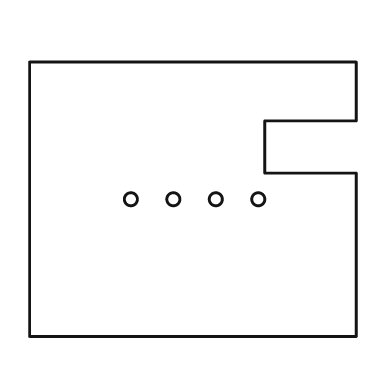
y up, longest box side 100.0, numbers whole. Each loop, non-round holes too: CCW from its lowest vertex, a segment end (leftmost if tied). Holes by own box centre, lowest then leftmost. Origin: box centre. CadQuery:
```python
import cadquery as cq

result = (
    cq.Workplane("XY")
    .moveTo(-50.0, -42.0)
    .lineTo(50.0, -42.0)
    .lineTo(50.0, 8.0)
    .lineTo(22.0, 8.0)
    .lineTo(22.0, 24.0)
    .lineTo(50.0, 24.0)
    .lineTo(50.0, 42.0)
    .lineTo(-50.0, 42.0)
    .close()
    .moveTo(-19.0, 0.0)
    .circle(2.0)
    .moveTo(-6.0, 0.0)
    .circle(2.0)
    .moveTo(7.0, 0.0)
    .circle(2.0)
    .moveTo(20.0, 0.0)
    .circle(2.0)
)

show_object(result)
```